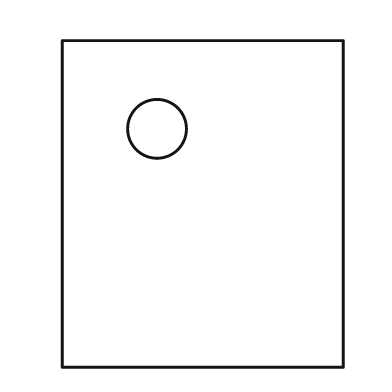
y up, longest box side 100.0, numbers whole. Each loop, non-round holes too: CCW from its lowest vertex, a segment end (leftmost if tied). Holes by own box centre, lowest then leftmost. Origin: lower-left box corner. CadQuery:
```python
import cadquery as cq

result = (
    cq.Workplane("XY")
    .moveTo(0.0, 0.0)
    .lineTo(86.0, 0.0)
    .lineTo(86.0, 100.0)
    .lineTo(0.0, 100.0)
    .close()
    .moveTo(29.0, 73.0)
    .circle(9.0)
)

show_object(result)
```